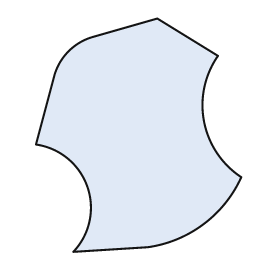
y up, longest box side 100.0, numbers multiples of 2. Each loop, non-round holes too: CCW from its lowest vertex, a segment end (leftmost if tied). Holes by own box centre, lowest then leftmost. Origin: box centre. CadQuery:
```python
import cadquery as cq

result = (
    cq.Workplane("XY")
    .moveTo(-28.0, -50.0)
    .lineTo(4.0, -48.0)
    .threePointArc((28.0, -38.0), (44.0, -18.0))
    .threePointArc((28.0, 6.0), (34.0, 34.0))
    .lineTo(8.0, 50.0)
    .lineTo(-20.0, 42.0)
    .threePointArc((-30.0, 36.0), (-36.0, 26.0))
    .lineTo(-44.0, -4.0)
    .threePointArc((-22.0, -22.0), (-28.0, -50.0))
    .close()
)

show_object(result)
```